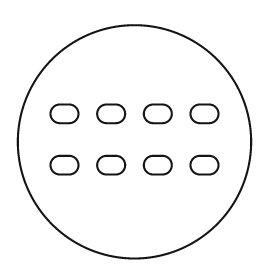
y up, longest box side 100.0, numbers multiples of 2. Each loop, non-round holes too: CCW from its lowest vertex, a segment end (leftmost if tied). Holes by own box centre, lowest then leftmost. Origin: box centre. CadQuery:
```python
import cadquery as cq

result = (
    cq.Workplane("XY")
    .moveTo(0.0, 0.0)
    .circle(50.0)
    .moveTo(-32.0, -14.0)
    .lineTo(-28.0, -14.0)
    .threePointArc((-24.0, -10.0), (-28.0, -6.0))
    .lineTo(-32.0, -6.0)
    .threePointArc((-36.0, -10.0), (-32.0, -14.0))
    .close()
    .moveTo(-12.0, -14.0)
    .lineTo(-8.0, -14.0)
    .threePointArc((-4.0, -10.0), (-8.0, -6.0))
    .lineTo(-12.0, -6.0)
    .threePointArc((-16.0, -10.0), (-12.0, -14.0))
    .close()
    .moveTo(8.0, -14.0)
    .lineTo(12.0, -14.0)
    .threePointArc((16.0, -10.0), (12.0, -6.0))
    .lineTo(8.0, -6.0)
    .threePointArc((4.0, -10.0), (8.0, -14.0))
    .close()
    .moveTo(28.0, -14.0)
    .lineTo(32.0, -14.0)
    .threePointArc((36.0, -10.0), (32.0, -6.0))
    .lineTo(28.0, -6.0)
    .threePointArc((24.0, -10.0), (28.0, -14.0))
    .close()
    .moveTo(-32.0, 8.0)
    .lineTo(-28.0, 8.0)
    .threePointArc((-24.0, 12.0), (-28.0, 16.0))
    .lineTo(-32.0, 16.0)
    .threePointArc((-36.0, 12.0), (-32.0, 8.0))
    .close()
    .moveTo(-12.0, 8.0)
    .lineTo(-8.0, 8.0)
    .threePointArc((-4.0, 12.0), (-8.0, 16.0))
    .lineTo(-12.0, 16.0)
    .threePointArc((-16.0, 12.0), (-12.0, 8.0))
    .close()
    .moveTo(8.0, 8.0)
    .lineTo(12.0, 8.0)
    .threePointArc((16.0, 12.0), (12.0, 16.0))
    .lineTo(8.0, 16.0)
    .threePointArc((4.0, 12.0), (8.0, 8.0))
    .close()
    .moveTo(28.0, 8.0)
    .lineTo(32.0, 8.0)
    .threePointArc((36.0, 12.0), (32.0, 16.0))
    .lineTo(28.0, 16.0)
    .threePointArc((24.0, 12.0), (28.0, 8.0))
    .close()
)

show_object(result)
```